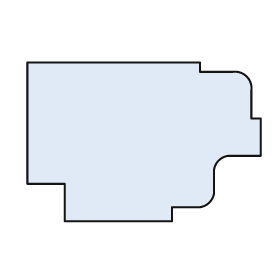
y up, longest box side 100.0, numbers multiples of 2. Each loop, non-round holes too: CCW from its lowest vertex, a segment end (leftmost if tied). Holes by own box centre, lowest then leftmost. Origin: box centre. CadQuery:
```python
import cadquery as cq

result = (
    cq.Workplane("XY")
    .moveTo(-34.0, -34.0)
    .lineTo(12.0, -34.0)
    .lineTo(12.0, -28.0)
    .lineTo(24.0, -28.0)
    .threePointArc((28.0, -26.0), (30.0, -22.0))
    .lineTo(30.0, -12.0)
    .threePointArc((32.0, -8.0), (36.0, -6.0))
    .lineTo(50.0, -6.0)
    .lineTo(50.0, 10.0)
    .lineTo(46.0, 10.0)
    .lineTo(46.0, 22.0)
    .threePointArc((44.0, 28.0), (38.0, 30.0))
    .lineTo(24.0, 30.0)
    .lineTo(24.0, 34.0)
    .lineTo(-50.0, 34.0)
    .lineTo(-50.0, -18.0)
    .lineTo(-34.0, -18.0)
    .close()
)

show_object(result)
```